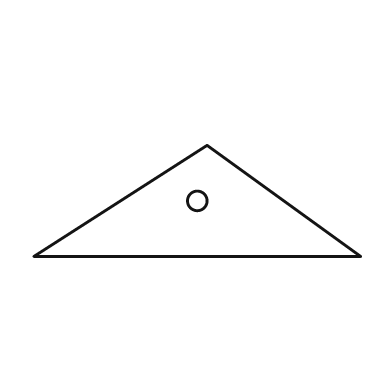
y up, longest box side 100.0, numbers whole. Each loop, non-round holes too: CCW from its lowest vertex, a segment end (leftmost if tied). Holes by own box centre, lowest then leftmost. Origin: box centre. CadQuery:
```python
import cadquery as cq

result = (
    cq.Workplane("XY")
    .moveTo(-50.0, -17.0)
    .lineTo(50.0, -17.0)
    .lineTo(3.0, 17.0)
    .close()
    .moveTo(0.0, 0.0)
    .circle(3.0)
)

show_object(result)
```